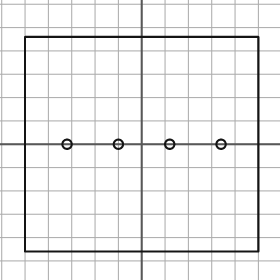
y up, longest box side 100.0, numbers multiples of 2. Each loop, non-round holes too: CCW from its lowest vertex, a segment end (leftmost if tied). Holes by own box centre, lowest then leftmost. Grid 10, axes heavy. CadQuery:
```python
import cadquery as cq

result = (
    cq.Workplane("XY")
    .moveTo(-50.0, -46.0)
    .lineTo(50.0, -46.0)
    .lineTo(50.0, 46.0)
    .lineTo(-50.0, 46.0)
    .close()
    .moveTo(-32.0, 0.0)
    .circle(2.0)
    .moveTo(-10.0, 0.0)
    .circle(2.0)
    .moveTo(12.0, 0.0)
    .circle(2.0)
    .moveTo(34.0, 0.0)
    .circle(2.0)
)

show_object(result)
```